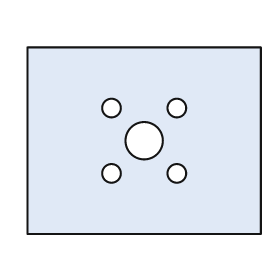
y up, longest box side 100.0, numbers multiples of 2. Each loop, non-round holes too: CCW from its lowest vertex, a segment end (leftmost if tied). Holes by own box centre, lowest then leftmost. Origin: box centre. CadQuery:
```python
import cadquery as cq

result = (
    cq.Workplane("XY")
    .moveTo(-50.0, -40.0)
    .lineTo(50.0, -40.0)
    .lineTo(50.0, 40.0)
    .lineTo(-50.0, 40.0)
    .close()
    .moveTo(-14.0, -14.0)
    .circle(4.0)
    .moveTo(14.0, -14.0)
    .circle(4.0)
    .moveTo(0.0, 0.0)
    .circle(8.0)
    .moveTo(-14.0, 14.0)
    .circle(4.0)
    .moveTo(14.0, 14.0)
    .circle(4.0)
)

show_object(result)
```